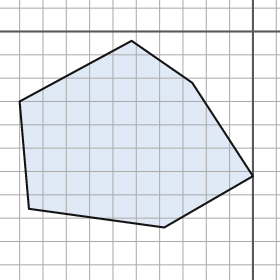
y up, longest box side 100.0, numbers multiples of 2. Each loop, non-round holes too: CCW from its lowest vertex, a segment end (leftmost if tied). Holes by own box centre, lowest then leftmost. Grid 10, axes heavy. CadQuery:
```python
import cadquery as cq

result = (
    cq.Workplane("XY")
    .moveTo(-38.0, -84.0)
    .lineTo(0.0, -62.0)
    .lineTo(-26.0, -22.0)
    .lineTo(-52.0, -4.0)
    .lineTo(-100.0, -30.0)
    .lineTo(-96.0, -76.0)
    .close()
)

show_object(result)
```